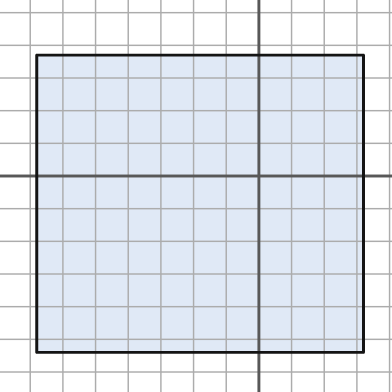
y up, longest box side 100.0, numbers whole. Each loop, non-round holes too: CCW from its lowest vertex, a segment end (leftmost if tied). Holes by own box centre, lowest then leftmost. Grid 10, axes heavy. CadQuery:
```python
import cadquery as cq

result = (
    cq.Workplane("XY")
    .moveTo(-68.0, -54.0)
    .lineTo(32.0, -54.0)
    .lineTo(32.0, 37.0)
    .lineTo(-68.0, 37.0)
    .close()
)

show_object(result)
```